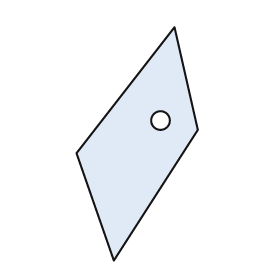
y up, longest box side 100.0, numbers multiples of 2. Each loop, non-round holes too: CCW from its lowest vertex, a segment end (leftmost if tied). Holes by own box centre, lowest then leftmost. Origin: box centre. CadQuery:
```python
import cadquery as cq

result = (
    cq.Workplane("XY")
    .moveTo(-10.0, -50.0)
    .lineTo(26.0, 6.0)
    .lineTo(16.0, 50.0)
    .lineTo(-26.0, -4.0)
    .close()
    .moveTo(10.0, 10.0)
    .circle(4.0)
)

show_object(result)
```